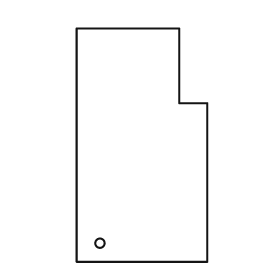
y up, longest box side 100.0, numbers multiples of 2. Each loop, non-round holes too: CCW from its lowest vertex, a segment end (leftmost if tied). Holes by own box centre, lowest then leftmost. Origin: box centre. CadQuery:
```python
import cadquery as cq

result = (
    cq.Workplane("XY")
    .moveTo(-28.0, -50.0)
    .lineTo(28.0, -50.0)
    .lineTo(28.0, 18.0)
    .lineTo(16.0, 18.0)
    .lineTo(16.0, 50.0)
    .lineTo(-28.0, 50.0)
    .close()
    .moveTo(-18.0, -42.0)
    .circle(2.0)
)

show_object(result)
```